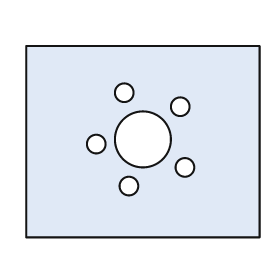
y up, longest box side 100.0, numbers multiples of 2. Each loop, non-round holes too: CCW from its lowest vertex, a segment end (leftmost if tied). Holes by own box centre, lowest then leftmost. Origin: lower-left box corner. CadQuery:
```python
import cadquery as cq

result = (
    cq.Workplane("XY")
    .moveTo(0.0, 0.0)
    .lineTo(100.0, 0.0)
    .lineTo(100.0, 82.0)
    .lineTo(0.0, 82.0)
    .close()
    .moveTo(44.0, 22.0)
    .circle(4.0)
    .moveTo(68.0, 30.0)
    .circle(4.0)
    .moveTo(30.0, 40.0)
    .circle(4.0)
    .moveTo(50.0, 42.0)
    .circle(12.0)
    .moveTo(66.0, 56.0)
    .circle(4.0)
    .moveTo(42.0, 62.0)
    .circle(4.0)
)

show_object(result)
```